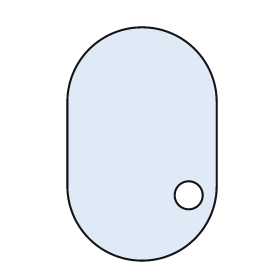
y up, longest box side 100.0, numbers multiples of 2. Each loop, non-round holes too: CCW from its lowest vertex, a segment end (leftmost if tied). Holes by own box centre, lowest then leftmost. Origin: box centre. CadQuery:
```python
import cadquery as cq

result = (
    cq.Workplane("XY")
    .moveTo(-32.0, -18.0)
    .threePointArc((0.0, -50.0), (32.0, -18.0))
    .lineTo(32.0, 18.0)
    .threePointArc((0.0, 50.0), (-32.0, 18.0))
    .close()
    .moveTo(20.0, -22.0)
    .circle(6.0)
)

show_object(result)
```